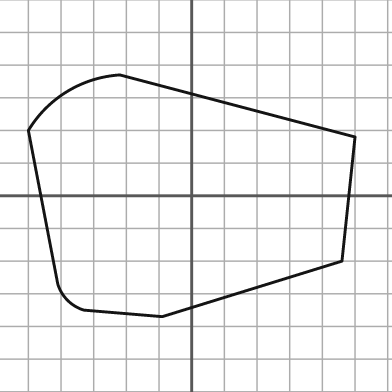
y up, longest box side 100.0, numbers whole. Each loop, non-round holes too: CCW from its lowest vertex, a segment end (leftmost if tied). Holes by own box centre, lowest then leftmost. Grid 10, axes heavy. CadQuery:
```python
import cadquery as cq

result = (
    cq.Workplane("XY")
    .moveTo(-9.0, -37.0)
    .lineTo(46.0, -20.0)
    .lineTo(50.0, 18.0)
    .lineTo(-22.0, 37.0)
    .threePointArc((-38.0, 32.0), (-50.0, 20.0))
    .lineTo(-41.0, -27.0)
    .threePointArc((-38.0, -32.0), (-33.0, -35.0))
    .close()
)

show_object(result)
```